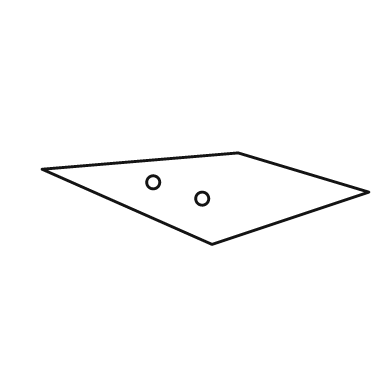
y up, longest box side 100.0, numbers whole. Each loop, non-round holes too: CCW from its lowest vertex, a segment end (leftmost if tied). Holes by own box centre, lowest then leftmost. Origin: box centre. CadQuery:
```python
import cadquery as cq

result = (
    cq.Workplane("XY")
    .moveTo(2.0, -14.0)
    .lineTo(50.0, 2.0)
    .lineTo(10.0, 14.0)
    .lineTo(-50.0, 9.0)
    .close()
    .moveTo(-1.0, 0.0)
    .circle(2.0)
    .moveTo(-16.0, 5.0)
    .circle(2.0)
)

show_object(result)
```